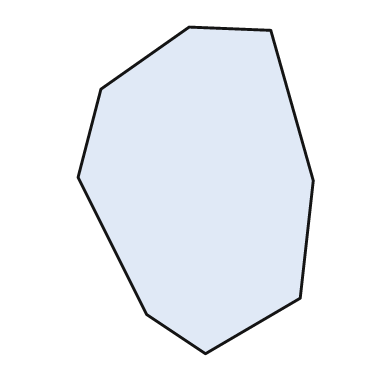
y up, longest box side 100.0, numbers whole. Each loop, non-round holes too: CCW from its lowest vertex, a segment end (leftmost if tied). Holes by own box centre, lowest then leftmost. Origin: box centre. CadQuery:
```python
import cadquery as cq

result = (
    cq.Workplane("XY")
    .moveTo(3.0, -50.0)
    .lineTo(32.0, -33.0)
    .lineTo(36.0, 3.0)
    .lineTo(23.0, 49.0)
    .lineTo(-2.0, 50.0)
    .lineTo(-29.0, 31.0)
    .lineTo(-36.0, 4.0)
    .lineTo(-15.0, -38.0)
    .close()
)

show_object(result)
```